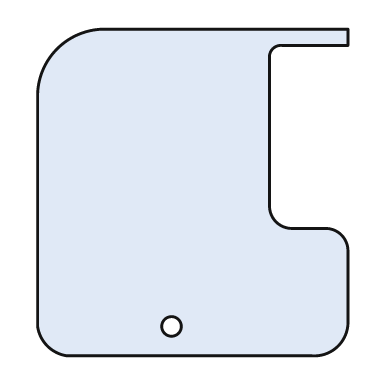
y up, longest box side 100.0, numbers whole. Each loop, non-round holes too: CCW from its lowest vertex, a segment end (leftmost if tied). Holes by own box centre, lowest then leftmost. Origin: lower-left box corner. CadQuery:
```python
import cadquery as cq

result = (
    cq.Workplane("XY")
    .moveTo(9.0, 0.0)
    .lineTo(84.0, 0.0)
    .threePointArc((92.0, 3.0), (95.0, 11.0))
    .lineTo(95.0, 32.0)
    .threePointArc((93.0, 37.0), (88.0, 39.0))
    .lineTo(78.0, 39.0)
    .threePointArc((73.0, 41.0), (71.0, 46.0))
    .lineTo(71.0, 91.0)
    .threePointArc((72.0, 94.0), (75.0, 95.0))
    .lineTo(95.0, 95.0)
    .lineTo(95.0, 100.0)
    .lineTo(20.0, 100.0)
    .threePointArc((6.0, 94.0), (0.0, 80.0))
    .lineTo(0.0, 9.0)
    .threePointArc((3.0, 3.0), (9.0, 0.0))
    .close()
    .moveTo(41.0, 9.0)
    .circle(3.0)
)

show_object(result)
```